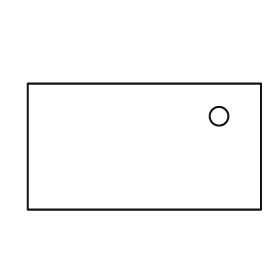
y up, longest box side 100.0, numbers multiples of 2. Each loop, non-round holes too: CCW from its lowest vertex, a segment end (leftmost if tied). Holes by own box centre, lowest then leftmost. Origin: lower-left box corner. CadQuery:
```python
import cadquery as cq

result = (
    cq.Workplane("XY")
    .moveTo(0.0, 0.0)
    .lineTo(100.0, 0.0)
    .lineTo(100.0, 54.0)
    .lineTo(0.0, 54.0)
    .close()
    .moveTo(82.0, 40.0)
    .circle(4.0)
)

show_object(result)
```